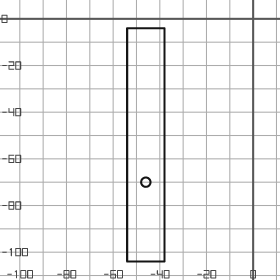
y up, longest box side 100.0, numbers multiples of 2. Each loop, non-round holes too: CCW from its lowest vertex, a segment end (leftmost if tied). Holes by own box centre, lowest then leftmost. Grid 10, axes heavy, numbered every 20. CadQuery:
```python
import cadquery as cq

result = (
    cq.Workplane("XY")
    .moveTo(-54.0, -104.0)
    .lineTo(-38.0, -104.0)
    .lineTo(-38.0, -4.0)
    .lineTo(-54.0, -4.0)
    .close()
    .moveTo(-46.0, -70.0)
    .circle(2.0)
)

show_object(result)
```